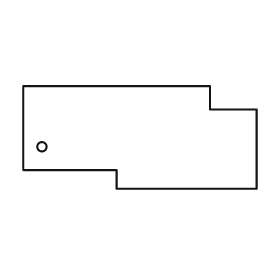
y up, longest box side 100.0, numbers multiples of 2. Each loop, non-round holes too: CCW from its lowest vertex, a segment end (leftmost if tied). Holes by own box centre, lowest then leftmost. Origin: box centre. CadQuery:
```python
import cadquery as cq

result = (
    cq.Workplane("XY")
    .moveTo(-10.0, -22.0)
    .lineTo(50.0, -22.0)
    .lineTo(50.0, 12.0)
    .lineTo(30.0, 12.0)
    .lineTo(30.0, 22.0)
    .lineTo(-50.0, 22.0)
    .lineTo(-50.0, -14.0)
    .lineTo(-10.0, -14.0)
    .close()
    .moveTo(-42.0, -4.0)
    .circle(2.0)
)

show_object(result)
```